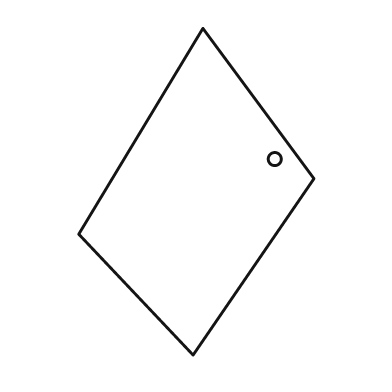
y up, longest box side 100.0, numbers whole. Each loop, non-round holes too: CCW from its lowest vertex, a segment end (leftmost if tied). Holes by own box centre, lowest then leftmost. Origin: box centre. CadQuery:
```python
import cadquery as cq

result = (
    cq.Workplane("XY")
    .moveTo(-1.0, -50.0)
    .lineTo(36.0, 4.0)
    .lineTo(2.0, 50.0)
    .lineTo(-36.0, -13.0)
    .close()
    .moveTo(24.0, 10.0)
    .circle(2.0)
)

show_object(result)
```